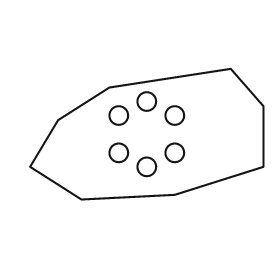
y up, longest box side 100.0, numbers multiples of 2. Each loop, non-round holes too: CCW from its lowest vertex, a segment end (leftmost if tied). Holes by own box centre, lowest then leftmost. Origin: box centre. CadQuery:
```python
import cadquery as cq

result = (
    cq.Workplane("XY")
    .moveTo(-28.0, -28.0)
    .lineTo(12.0, -26.0)
    .lineTo(50.0, -14.0)
    .lineTo(50.0, 12.0)
    .lineTo(36.0, 28.0)
    .lineTo(-16.0, 20.0)
    .lineTo(-38.0, 6.0)
    .lineTo(-50.0, -14.0)
    .close()
    .moveTo(0.0, -14.0)
    .circle(4.0)
    .moveTo(-12.0, -8.0)
    .circle(4.0)
    .moveTo(12.0, -8.0)
    .circle(4.0)
    .moveTo(-12.0, 8.0)
    .circle(4.0)
    .moveTo(12.0, 8.0)
    .circle(4.0)
    .moveTo(0.0, 14.0)
    .circle(4.0)
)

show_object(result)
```